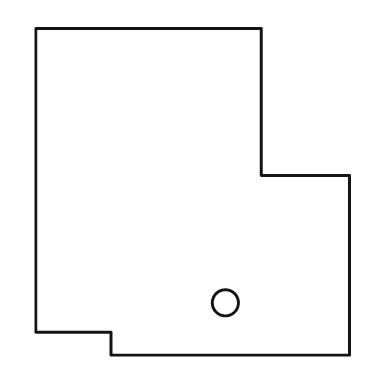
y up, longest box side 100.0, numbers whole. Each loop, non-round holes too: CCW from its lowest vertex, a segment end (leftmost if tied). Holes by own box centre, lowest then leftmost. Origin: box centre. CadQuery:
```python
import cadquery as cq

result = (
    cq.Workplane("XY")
    .moveTo(-25.0, -50.0)
    .lineTo(48.0, -50.0)
    .lineTo(48.0, 5.0)
    .lineTo(21.0, 5.0)
    .lineTo(21.0, 50.0)
    .lineTo(-48.0, 50.0)
    .lineTo(-48.0, -43.0)
    .lineTo(-25.0, -43.0)
    .close()
    .moveTo(10.0, -34.0)
    .circle(4.0)
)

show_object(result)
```